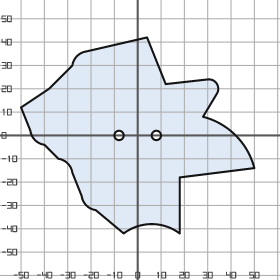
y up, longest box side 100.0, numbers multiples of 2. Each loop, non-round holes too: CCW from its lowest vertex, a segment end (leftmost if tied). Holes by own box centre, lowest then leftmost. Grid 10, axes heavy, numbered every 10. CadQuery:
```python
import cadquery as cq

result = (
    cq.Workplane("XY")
    .moveTo(-6.0, -42.0)
    .threePointArc((6.0, -38.0), (18.0, -42.0))
    .lineTo(18.0, -18.0)
    .lineTo(50.0, -14.0)
    .threePointArc((42.0, 0.0), (28.0, 8.0))
    .lineTo(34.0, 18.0)
    .threePointArc((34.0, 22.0), (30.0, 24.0))
    .lineTo(12.0, 22.0)
    .lineTo(4.0, 42.0)
    .lineTo(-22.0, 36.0)
    .threePointArc((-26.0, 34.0), (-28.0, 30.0))
    .lineTo(-38.0, 20.0)
    .lineTo(-50.0, 12.0)
    .lineTo(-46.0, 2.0)
    .threePointArc((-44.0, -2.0), (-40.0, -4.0))
    .lineTo(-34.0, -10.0)
    .threePointArc((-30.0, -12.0), (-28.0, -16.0))
    .lineTo(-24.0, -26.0)
    .threePointArc((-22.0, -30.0), (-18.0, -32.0))
    .close()
    .moveTo(-8.0, 0.0)
    .circle(2.0)
    .moveTo(8.0, 0.0)
    .circle(2.0)
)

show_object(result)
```